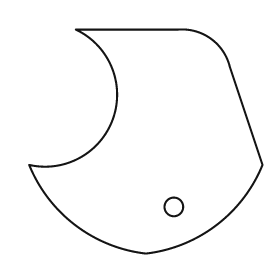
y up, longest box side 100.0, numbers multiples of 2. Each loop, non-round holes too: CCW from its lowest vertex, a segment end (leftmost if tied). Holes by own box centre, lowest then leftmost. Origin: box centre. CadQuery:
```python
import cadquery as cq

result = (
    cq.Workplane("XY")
    .moveTo(0.0, -48.0)
    .threePointArc((30.0, -36.0), (50.0, -10.0))
    .lineTo(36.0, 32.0)
    .threePointArc((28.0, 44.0), (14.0, 48.0))
    .lineTo(-30.0, 48.0)
    .threePointArc((-14.0, 10.0), (-50.0, -10.0))
    .threePointArc((-30.0, -36.0), (0.0, -48.0))
    .close()
    .moveTo(12.0, -28.0)
    .circle(4.0)
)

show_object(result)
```